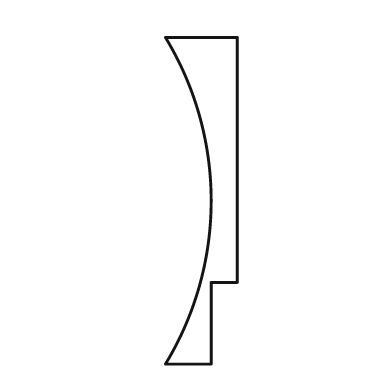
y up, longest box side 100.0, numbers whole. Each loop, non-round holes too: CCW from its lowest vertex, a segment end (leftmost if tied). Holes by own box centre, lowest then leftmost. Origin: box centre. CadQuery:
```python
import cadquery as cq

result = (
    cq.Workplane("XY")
    .moveTo(-11.0, -50.0)
    .lineTo(3.0, -50.0)
    .lineTo(3.0, -25.0)
    .lineTo(11.0, -25.0)
    .lineTo(11.0, 50.0)
    .lineTo(-11.0, 50.0)
    .threePointArc((3.0, 0.0), (-11.0, -50.0))
    .close()
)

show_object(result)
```